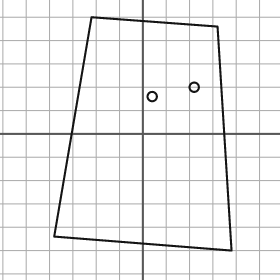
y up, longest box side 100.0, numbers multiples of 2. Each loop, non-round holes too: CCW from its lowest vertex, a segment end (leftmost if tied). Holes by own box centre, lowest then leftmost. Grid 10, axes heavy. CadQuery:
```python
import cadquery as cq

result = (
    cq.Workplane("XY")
    .moveTo(38.0, -50.0)
    .lineTo(32.0, 46.0)
    .lineTo(-22.0, 50.0)
    .lineTo(-38.0, -44.0)
    .close()
    .moveTo(4.0, 16.0)
    .circle(2.0)
    .moveTo(22.0, 20.0)
    .circle(2.0)
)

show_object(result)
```